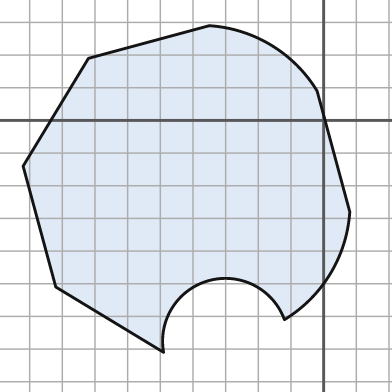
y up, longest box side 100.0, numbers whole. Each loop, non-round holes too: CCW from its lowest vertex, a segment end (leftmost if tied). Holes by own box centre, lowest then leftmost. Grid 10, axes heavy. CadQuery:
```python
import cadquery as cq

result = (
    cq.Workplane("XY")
    .moveTo(-49.0, -71.0)
    .threePointArc((-35.0, -49.0), (-12.0, -61.0))
    .threePointArc((2.0, -47.0), (8.0, -28.0))
    .lineTo(-2.0, 9.0)
    .threePointArc((-16.0, 23.0), (-35.0, 29.0))
    .lineTo(-72.0, 19.0)
    .lineTo(-92.0, -14.0)
    .lineTo(-82.0, -51.0)
    .close()
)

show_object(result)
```